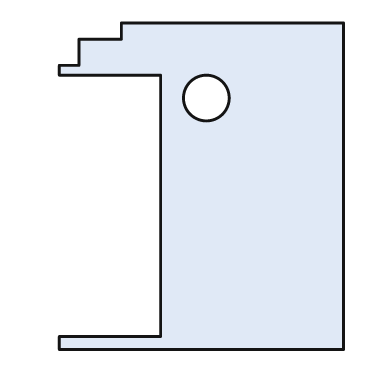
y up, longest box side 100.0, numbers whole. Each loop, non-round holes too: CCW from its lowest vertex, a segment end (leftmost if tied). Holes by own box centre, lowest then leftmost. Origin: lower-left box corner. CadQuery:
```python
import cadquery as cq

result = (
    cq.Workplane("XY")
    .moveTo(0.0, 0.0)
    .lineTo(87.0, 0.0)
    .lineTo(87.0, 100.0)
    .lineTo(19.0, 100.0)
    .lineTo(19.0, 95.0)
    .lineTo(6.0, 95.0)
    .lineTo(6.0, 87.0)
    .lineTo(0.0, 87.0)
    .lineTo(0.0, 84.0)
    .lineTo(31.0, 84.0)
    .lineTo(31.0, 4.0)
    .lineTo(0.0, 4.0)
    .close()
    .moveTo(45.0, 77.0)
    .circle(7.0)
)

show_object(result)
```